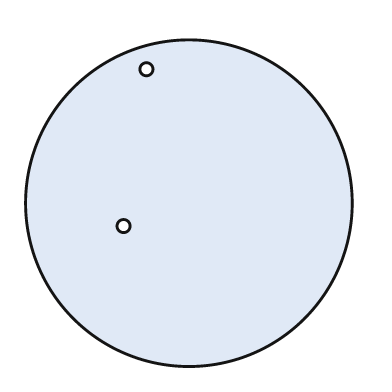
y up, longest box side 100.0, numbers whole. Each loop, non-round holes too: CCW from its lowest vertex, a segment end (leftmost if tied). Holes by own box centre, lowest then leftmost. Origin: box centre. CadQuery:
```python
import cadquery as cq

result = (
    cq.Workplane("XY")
    .moveTo(0.0, 0.0)
    .circle(50.0)
    .moveTo(-20.0, -7.0)
    .circle(2.0)
    .moveTo(-13.0, 41.0)
    .circle(2.0)
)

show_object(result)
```